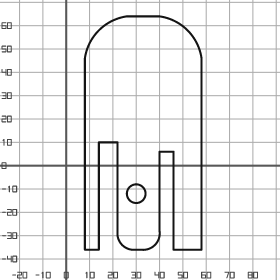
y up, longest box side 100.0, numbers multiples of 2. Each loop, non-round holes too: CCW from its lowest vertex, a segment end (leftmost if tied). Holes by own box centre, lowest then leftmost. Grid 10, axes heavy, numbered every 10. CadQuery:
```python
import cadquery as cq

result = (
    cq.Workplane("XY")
    .moveTo(8.0, -36.0)
    .lineTo(14.0, -36.0)
    .lineTo(14.0, 10.0)
    .lineTo(22.0, 10.0)
    .lineTo(22.0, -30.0)
    .threePointArc((24.0, -34.0), (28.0, -36.0))
    .lineTo(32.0, -36.0)
    .threePointArc((38.0, -34.0), (40.0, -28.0))
    .lineTo(40.0, 6.0)
    .lineTo(46.0, 6.0)
    .lineTo(46.0, -36.0)
    .lineTo(58.0, -36.0)
    .lineTo(58.0, 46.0)
    .threePointArc((52.0, 58.0), (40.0, 64.0))
    .lineTo(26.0, 64.0)
    .threePointArc((14.0, 58.0), (8.0, 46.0))
    .close()
    .moveTo(30.0, -12.0)
    .circle(4.0)
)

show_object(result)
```